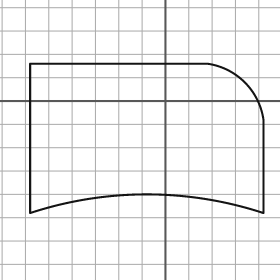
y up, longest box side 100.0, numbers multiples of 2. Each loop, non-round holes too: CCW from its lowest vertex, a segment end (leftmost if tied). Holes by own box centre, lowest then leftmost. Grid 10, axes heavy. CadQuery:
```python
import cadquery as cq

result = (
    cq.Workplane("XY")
    .moveTo(-58.0, -48.0)
    .threePointArc((-8.0, -40.0), (42.0, -48.0))
    .lineTo(42.0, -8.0)
    .threePointArc((34.0, 8.0), (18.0, 16.0))
    .lineTo(-58.0, 16.0)
    .close()
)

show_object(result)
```